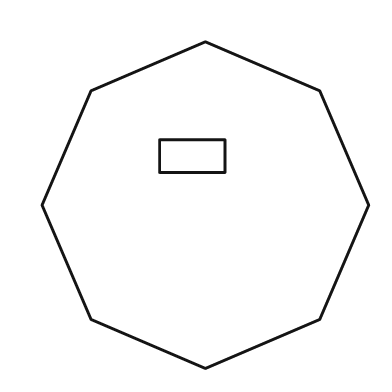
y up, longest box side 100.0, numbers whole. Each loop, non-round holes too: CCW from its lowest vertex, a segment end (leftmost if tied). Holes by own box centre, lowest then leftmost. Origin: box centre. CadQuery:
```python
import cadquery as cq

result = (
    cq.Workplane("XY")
    .moveTo(0.0, -50.0)
    .lineTo(35.0, -35.0)
    .lineTo(50.0, 0.0)
    .lineTo(35.0, 35.0)
    .lineTo(0.0, 50.0)
    .lineTo(-35.0, 35.0)
    .lineTo(-50.0, 0.0)
    .lineTo(-35.0, -35.0)
    .close()
    .moveTo(-14.0, 10.0)
    .lineTo(6.0, 10.0)
    .lineTo(6.0, 20.0)
    .lineTo(-14.0, 20.0)
    .close()
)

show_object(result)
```